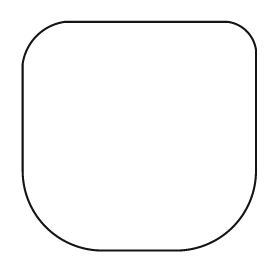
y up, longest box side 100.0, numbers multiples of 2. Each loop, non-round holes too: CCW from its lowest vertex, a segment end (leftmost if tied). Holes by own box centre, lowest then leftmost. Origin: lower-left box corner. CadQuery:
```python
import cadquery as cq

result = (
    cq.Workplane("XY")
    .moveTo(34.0, 0.0)
    .lineTo(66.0, 0.0)
    .threePointArc((90.0, 10.0), (100.0, 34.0))
    .lineTo(100.0, 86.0)
    .threePointArc((96.0, 94.0), (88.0, 98.0))
    .lineTo(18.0, 98.0)
    .threePointArc((6.0, 92.0), (0.0, 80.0))
    .lineTo(0.0, 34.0)
    .threePointArc((10.0, 10.0), (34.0, 0.0))
    .close()
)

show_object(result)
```